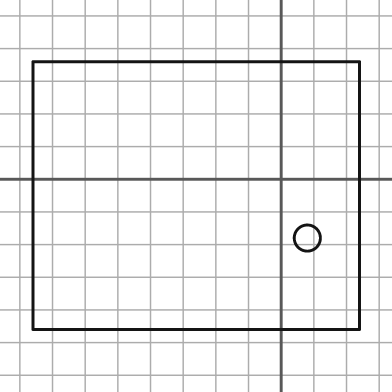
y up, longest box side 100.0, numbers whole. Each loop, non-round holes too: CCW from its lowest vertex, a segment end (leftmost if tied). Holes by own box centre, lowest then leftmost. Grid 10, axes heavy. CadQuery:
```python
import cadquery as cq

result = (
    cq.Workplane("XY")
    .moveTo(-76.0, -46.0)
    .lineTo(24.0, -46.0)
    .lineTo(24.0, 36.0)
    .lineTo(-76.0, 36.0)
    .close()
    .moveTo(8.0, -18.0)
    .circle(4.0)
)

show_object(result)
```